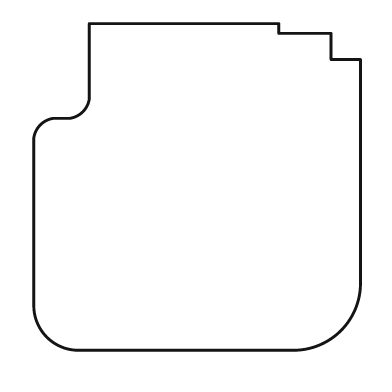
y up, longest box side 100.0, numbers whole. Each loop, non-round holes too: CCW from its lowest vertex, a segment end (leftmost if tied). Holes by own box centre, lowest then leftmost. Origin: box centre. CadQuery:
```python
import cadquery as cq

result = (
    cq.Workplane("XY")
    .moveTo(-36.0, -50.0)
    .lineTo(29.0, -50.0)
    .threePointArc((44.0, -44.0), (50.0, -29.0))
    .lineTo(50.0, 39.0)
    .lineTo(41.0, 39.0)
    .lineTo(41.0, 47.0)
    .lineTo(25.0, 47.0)
    .lineTo(25.0, 50.0)
    .lineTo(-33.0, 50.0)
    .lineTo(-33.0, 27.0)
    .threePointArc((-35.0, 23.0), (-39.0, 21.0))
    .lineTo(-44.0, 21.0)
    .threePointArc((-48.0, 19.0), (-50.0, 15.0))
    .lineTo(-50.0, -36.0)
    .threePointArc((-46.0, -46.0), (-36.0, -50.0))
    .close()
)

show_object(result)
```